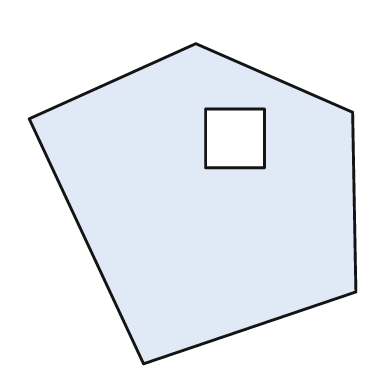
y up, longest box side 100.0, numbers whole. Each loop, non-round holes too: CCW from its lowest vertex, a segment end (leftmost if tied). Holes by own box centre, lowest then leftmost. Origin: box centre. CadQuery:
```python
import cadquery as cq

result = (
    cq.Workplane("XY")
    .moveTo(-15.0, -49.0)
    .lineTo(50.0, -27.0)
    .lineTo(49.0, 28.0)
    .lineTo(1.0, 49.0)
    .lineTo(-50.0, 26.0)
    .close()
    .moveTo(4.0, 11.0)
    .lineTo(22.0, 11.0)
    .lineTo(22.0, 29.0)
    .lineTo(4.0, 29.0)
    .close()
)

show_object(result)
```